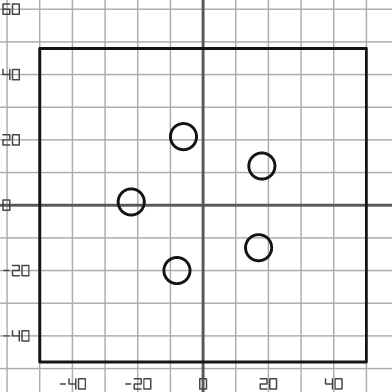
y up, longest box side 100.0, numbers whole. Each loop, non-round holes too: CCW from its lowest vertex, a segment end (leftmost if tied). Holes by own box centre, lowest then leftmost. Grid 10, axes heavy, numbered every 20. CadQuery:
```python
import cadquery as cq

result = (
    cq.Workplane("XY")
    .moveTo(-50.0, -48.0)
    .lineTo(50.0, -48.0)
    .lineTo(50.0, 48.0)
    .lineTo(-50.0, 48.0)
    .close()
    .moveTo(-8.0, -20.0)
    .circle(4.0)
    .moveTo(17.0, -13.0)
    .circle(4.0)
    .moveTo(-22.0, 1.0)
    .circle(4.0)
    .moveTo(18.0, 12.0)
    .circle(4.0)
    .moveTo(-6.0, 21.0)
    .circle(4.0)
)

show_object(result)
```